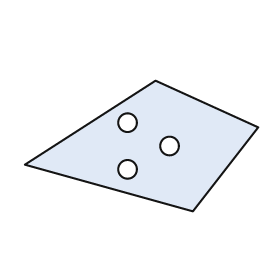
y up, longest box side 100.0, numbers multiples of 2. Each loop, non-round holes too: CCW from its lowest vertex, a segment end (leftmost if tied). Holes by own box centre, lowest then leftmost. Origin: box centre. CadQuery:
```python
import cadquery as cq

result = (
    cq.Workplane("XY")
    .moveTo(22.0, -28.0)
    .lineTo(50.0, 8.0)
    .lineTo(6.0, 28.0)
    .lineTo(-50.0, -8.0)
    .close()
    .moveTo(-6.0, -10.0)
    .circle(4.0)
    .moveTo(12.0, 0.0)
    .circle(4.0)
    .moveTo(-6.0, 10.0)
    .circle(4.0)
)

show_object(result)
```